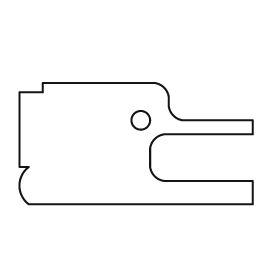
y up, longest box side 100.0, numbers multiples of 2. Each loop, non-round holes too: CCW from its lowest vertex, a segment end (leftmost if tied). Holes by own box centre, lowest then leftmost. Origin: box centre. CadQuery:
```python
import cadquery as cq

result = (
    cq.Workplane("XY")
    .moveTo(-46.0, -26.0)
    .lineTo(50.0, -26.0)
    .lineTo(50.0, -16.0)
    .lineTo(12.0, -16.0)
    .threePointArc((8.0, -14.0), (6.0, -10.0))
    .lineTo(6.0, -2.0)
    .threePointArc((8.0, 2.0), (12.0, 4.0))
    .lineTo(50.0, 4.0)
    .lineTo(50.0, 10.0)
    .lineTo(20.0, 10.0)
    .threePointArc((16.0, 12.0), (14.0, 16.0))
    .lineTo(14.0, 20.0)
    .threePointArc((12.0, 24.0), (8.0, 26.0))
    .lineTo(-40.0, 26.0)
    .lineTo(-40.0, 22.0)
    .lineTo(-50.0, 22.0)
    .lineTo(-50.0, -10.0)
    .lineTo(-46.0, -10.0)
    .threePointArc((-50.0, -18.0), (-46.0, -26.0))
    .close()
    .moveTo(2.0, 10.0)
    .circle(4.0)
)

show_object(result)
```